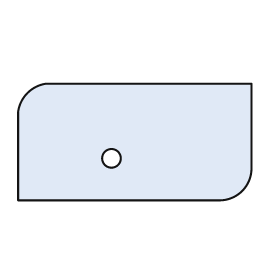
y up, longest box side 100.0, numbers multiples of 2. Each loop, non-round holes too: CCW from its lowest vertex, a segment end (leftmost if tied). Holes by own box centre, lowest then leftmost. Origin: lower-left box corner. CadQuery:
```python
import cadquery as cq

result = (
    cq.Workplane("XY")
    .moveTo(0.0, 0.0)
    .lineTo(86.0, 0.0)
    .threePointArc((96.0, 4.0), (100.0, 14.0))
    .lineTo(100.0, 50.0)
    .lineTo(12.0, 50.0)
    .threePointArc((4.0, 46.0), (0.0, 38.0))
    .close()
    .moveTo(40.0, 18.0)
    .circle(4.0)
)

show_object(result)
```